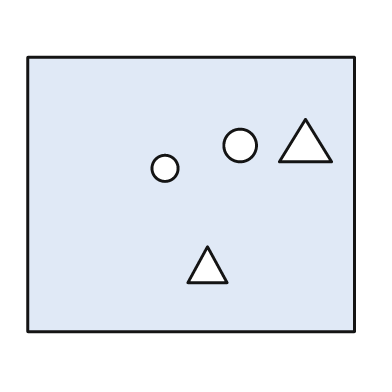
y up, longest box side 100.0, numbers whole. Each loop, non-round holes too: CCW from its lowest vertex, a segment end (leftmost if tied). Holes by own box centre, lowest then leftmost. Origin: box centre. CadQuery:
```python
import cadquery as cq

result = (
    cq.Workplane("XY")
    .moveTo(-50.0, -42.0)
    .lineTo(50.0, -42.0)
    .lineTo(50.0, 42.0)
    .lineTo(-50.0, 42.0)
    .close()
    .moveTo(-1.0, -27.0)
    .lineTo(11.0, -27.0)
    .lineTo(5.0, -16.0)
    .close()
    .moveTo(-8.0, 8.0)
    .circle(4.0)
    .moveTo(15.0, 15.0)
    .circle(5.0)
    .moveTo(27.0, 10.0)
    .lineTo(43.0, 10.0)
    .lineTo(35.0, 23.0)
    .close()
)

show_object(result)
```